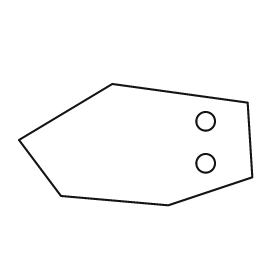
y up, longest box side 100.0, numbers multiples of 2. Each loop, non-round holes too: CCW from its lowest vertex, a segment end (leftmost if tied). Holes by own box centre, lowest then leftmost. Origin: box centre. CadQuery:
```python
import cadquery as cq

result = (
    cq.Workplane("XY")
    .moveTo(14.0, -26.0)
    .lineTo(50.0, -14.0)
    .lineTo(48.0, 18.0)
    .lineTo(-10.0, 26.0)
    .lineTo(-50.0, 2.0)
    .lineTo(-32.0, -22.0)
    .close()
    .moveTo(30.0, -8.0)
    .circle(4.0)
    .moveTo(30.0, 10.0)
    .circle(4.0)
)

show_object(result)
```